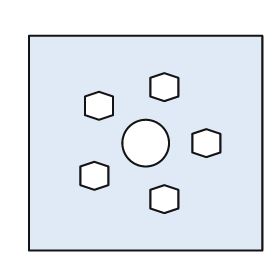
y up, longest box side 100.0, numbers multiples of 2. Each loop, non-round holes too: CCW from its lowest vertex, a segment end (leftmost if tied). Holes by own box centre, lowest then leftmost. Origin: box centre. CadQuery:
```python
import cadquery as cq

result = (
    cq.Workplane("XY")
    .moveTo(-50.0, -46.0)
    .lineTo(50.0, -46.0)
    .lineTo(50.0, 46.0)
    .lineTo(-50.0, 46.0)
    .close()
    .moveTo(8.0, -30.0)
    .lineTo(14.0, -28.0)
    .lineTo(14.0, -20.0)
    .lineTo(8.0, -18.0)
    .lineTo(2.0, -20.0)
    .lineTo(2.0, -28.0)
    .close()
    .moveTo(-22.0, -20.0)
    .lineTo(-16.0, -18.0)
    .lineTo(-16.0, -10.0)
    .lineTo(-22.0, -8.0)
    .lineTo(-28.0, -10.0)
    .lineTo(-28.0, -18.0)
    .close()
    .moveTo(0.0, 0.0)
    .circle(10.0)
    .moveTo(26.0, -6.0)
    .lineTo(32.0, -4.0)
    .lineTo(32.0, 4.0)
    .lineTo(26.0, 6.0)
    .lineTo(20.0, 4.0)
    .lineTo(20.0, -4.0)
    .close()
    .moveTo(-20.0, 10.0)
    .lineTo(-14.0, 12.0)
    .lineTo(-14.0, 20.0)
    .lineTo(-20.0, 22.0)
    .lineTo(-26.0, 20.0)
    .lineTo(-26.0, 12.0)
    .close()
    .moveTo(8.0, 18.0)
    .lineTo(14.0, 20.0)
    .lineTo(14.0, 28.0)
    .lineTo(8.0, 30.0)
    .lineTo(2.0, 28.0)
    .lineTo(2.0, 20.0)
    .close()
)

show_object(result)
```